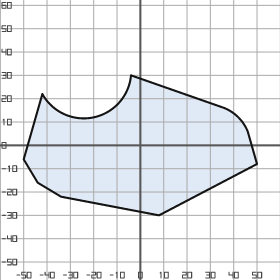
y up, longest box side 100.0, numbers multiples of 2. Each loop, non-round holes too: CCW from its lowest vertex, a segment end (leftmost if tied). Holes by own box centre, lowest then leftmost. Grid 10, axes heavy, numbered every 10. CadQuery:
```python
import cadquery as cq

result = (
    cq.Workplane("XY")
    .moveTo(8.0, -30.0)
    .lineTo(50.0, -8.0)
    .lineTo(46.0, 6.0)
    .threePointArc((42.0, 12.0), (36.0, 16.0))
    .lineTo(-4.0, 30.0)
    .threePointArc((-20.0, 12.0), (-42.0, 22.0))
    .lineTo(-50.0, -6.0)
    .lineTo(-44.0, -16.0)
    .lineTo(-34.0, -22.0)
    .close()
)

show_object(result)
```